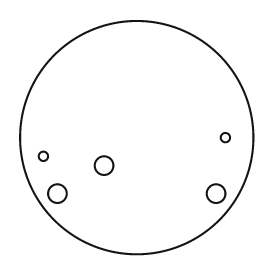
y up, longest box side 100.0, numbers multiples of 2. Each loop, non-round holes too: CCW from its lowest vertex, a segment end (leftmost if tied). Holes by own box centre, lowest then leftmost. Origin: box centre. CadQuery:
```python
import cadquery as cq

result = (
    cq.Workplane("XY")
    .moveTo(0.0, 0.0)
    .circle(50.0)
    .moveTo(-34.0, -24.0)
    .circle(4.0)
    .moveTo(34.0, -24.0)
    .circle(4.0)
    .moveTo(-14.0, -12.0)
    .circle(4.0)
    .moveTo(-40.0, -8.0)
    .circle(2.0)
    .moveTo(38.0, 0.0)
    .circle(2.0)
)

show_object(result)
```